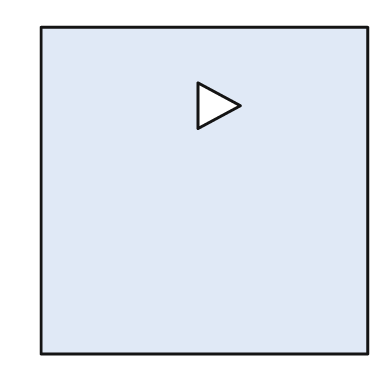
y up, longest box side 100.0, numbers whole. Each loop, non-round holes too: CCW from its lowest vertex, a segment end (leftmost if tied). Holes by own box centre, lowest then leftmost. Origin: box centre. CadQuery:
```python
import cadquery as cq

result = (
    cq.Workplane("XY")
    .moveTo(-50.0, -50.0)
    .lineTo(50.0, -50.0)
    .lineTo(50.0, 50.0)
    .lineTo(-50.0, 50.0)
    .close()
    .moveTo(-2.0, 19.0)
    .lineTo(11.0, 26.0)
    .lineTo(-2.0, 33.0)
    .close()
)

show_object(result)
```